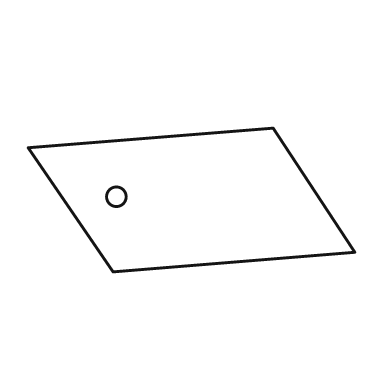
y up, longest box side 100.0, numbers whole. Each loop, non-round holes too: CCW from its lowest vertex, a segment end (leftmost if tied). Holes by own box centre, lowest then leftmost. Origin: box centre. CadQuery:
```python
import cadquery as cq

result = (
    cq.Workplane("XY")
    .moveTo(-24.0, -22.0)
    .lineTo(50.0, -16.0)
    .lineTo(25.0, 22.0)
    .lineTo(-50.0, 16.0)
    .close()
    .moveTo(-23.0, 1.0)
    .circle(3.0)
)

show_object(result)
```